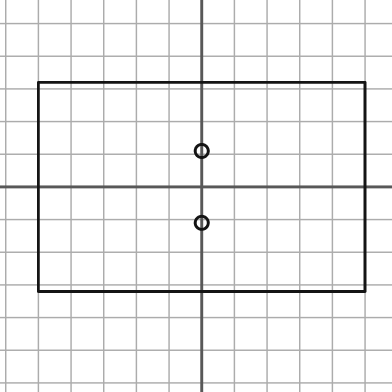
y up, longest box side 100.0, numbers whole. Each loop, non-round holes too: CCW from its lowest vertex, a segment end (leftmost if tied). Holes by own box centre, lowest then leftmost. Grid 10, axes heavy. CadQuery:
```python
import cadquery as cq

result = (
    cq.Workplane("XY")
    .moveTo(-50.0, -32.0)
    .lineTo(50.0, -32.0)
    .lineTo(50.0, 32.0)
    .lineTo(-50.0, 32.0)
    .close()
    .moveTo(0.0, -11.0)
    .circle(2.0)
    .moveTo(0.0, 11.0)
    .circle(2.0)
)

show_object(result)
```